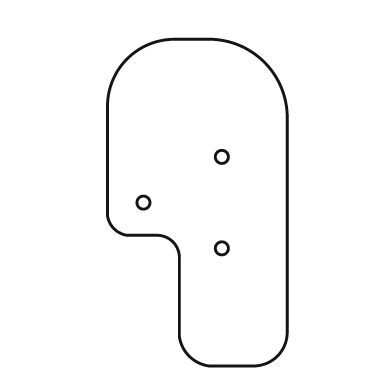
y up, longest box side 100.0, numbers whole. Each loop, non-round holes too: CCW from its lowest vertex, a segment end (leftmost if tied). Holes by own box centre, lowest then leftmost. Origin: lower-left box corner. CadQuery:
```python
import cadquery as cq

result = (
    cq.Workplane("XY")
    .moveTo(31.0, 0.0)
    .lineTo(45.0, 0.0)
    .threePointArc((52.0, 3.0), (55.0, 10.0))
    .lineTo(55.0, 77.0)
    .threePointArc((48.0, 93.0), (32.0, 100.0))
    .lineTo(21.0, 100.0)
    .threePointArc((6.0, 94.0), (0.0, 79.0))
    .lineTo(0.0, 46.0)
    .threePointArc((2.0, 42.0), (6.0, 40.0))
    .lineTo(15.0, 40.0)
    .threePointArc((20.0, 38.0), (22.0, 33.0))
    .lineTo(22.0, 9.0)
    .threePointArc((25.0, 3.0), (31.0, 0.0))
    .close()
    .moveTo(35.0, 36.0)
    .circle(2.0)
    .moveTo(11.0, 50.0)
    .circle(2.0)
    .moveTo(35.0, 64.0)
    .circle(2.0)
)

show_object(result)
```